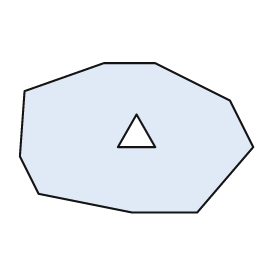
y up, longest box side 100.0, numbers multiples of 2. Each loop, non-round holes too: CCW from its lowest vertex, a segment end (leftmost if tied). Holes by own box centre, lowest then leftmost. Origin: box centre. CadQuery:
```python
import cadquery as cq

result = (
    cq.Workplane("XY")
    .moveTo(-2.0, -32.0)
    .lineTo(26.0, -32.0)
    .lineTo(50.0, -4.0)
    .lineTo(40.0, 16.0)
    .lineTo(8.0, 32.0)
    .lineTo(-14.0, 32.0)
    .lineTo(-48.0, 20.0)
    .lineTo(-50.0, -8.0)
    .lineTo(-42.0, -24.0)
    .close()
    .moveTo(-8.0, -4.0)
    .lineTo(8.0, -4.0)
    .lineTo(0.0, 10.0)
    .close()
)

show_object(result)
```